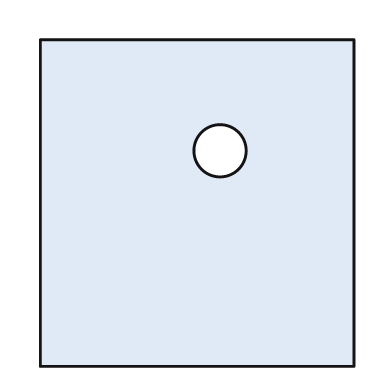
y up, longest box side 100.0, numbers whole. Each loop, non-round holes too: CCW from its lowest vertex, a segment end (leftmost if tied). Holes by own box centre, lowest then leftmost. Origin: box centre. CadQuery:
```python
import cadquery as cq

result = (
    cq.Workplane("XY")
    .moveTo(-48.0, -50.0)
    .lineTo(48.0, -50.0)
    .lineTo(48.0, 50.0)
    .lineTo(-48.0, 50.0)
    .close()
    .moveTo(7.0, 16.0)
    .circle(8.0)
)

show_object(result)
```